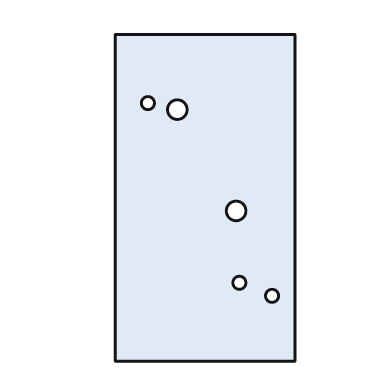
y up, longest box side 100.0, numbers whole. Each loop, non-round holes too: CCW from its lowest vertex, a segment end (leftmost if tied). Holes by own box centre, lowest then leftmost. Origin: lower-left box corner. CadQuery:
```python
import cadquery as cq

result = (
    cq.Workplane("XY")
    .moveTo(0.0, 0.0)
    .lineTo(55.0, 0.0)
    .lineTo(55.0, 100.0)
    .lineTo(0.0, 100.0)
    .close()
    .moveTo(48.0, 20.0)
    .circle(2.0)
    .moveTo(38.0, 24.0)
    .circle(2.0)
    .moveTo(37.0, 46.0)
    .circle(3.0)
    .moveTo(19.0, 77.0)
    .circle(3.0)
    .moveTo(10.0, 79.0)
    .circle(2.0)
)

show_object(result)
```